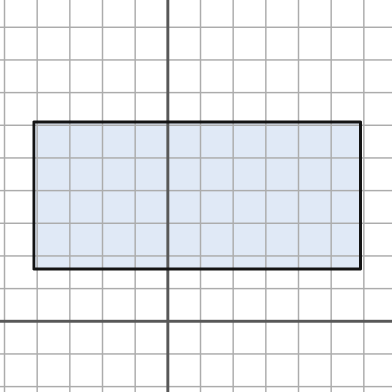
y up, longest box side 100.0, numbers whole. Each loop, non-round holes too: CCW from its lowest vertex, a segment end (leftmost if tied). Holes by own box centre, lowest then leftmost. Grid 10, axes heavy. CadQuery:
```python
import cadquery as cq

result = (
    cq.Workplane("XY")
    .moveTo(-41.0, 16.0)
    .lineTo(59.0, 16.0)
    .lineTo(59.0, 61.0)
    .lineTo(-41.0, 61.0)
    .close()
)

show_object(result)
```